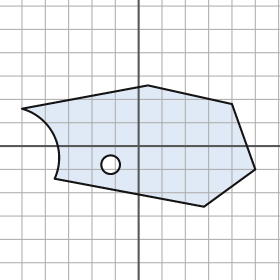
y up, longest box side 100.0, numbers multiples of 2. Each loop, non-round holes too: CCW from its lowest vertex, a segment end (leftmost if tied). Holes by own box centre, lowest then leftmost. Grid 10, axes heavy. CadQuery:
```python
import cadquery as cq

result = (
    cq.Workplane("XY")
    .moveTo(28.0, -26.0)
    .lineTo(50.0, -10.0)
    .lineTo(40.0, 18.0)
    .lineTo(4.0, 26.0)
    .lineTo(-50.0, 16.0)
    .threePointArc((-36.0, 4.0), (-36.0, -14.0))
    .close()
    .moveTo(-12.0, -8.0)
    .circle(4.0)
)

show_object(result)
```